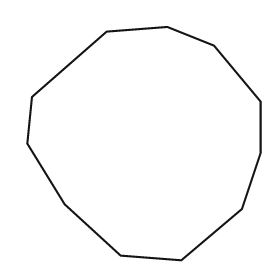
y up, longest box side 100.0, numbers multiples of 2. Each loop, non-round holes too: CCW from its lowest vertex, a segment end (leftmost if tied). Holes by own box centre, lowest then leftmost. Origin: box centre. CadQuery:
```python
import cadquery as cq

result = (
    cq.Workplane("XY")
    .moveTo(16.0, -50.0)
    .lineTo(42.0, -28.0)
    .lineTo(50.0, -4.0)
    .lineTo(50.0, 18.0)
    .lineTo(30.0, 42.0)
    .lineTo(10.0, 50.0)
    .lineTo(-16.0, 48.0)
    .lineTo(-48.0, 20.0)
    .lineTo(-50.0, 0.0)
    .lineTo(-34.0, -26.0)
    .lineTo(-10.0, -48.0)
    .close()
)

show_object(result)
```